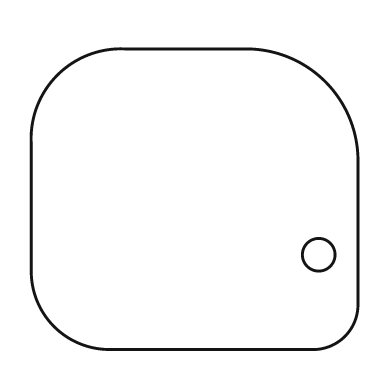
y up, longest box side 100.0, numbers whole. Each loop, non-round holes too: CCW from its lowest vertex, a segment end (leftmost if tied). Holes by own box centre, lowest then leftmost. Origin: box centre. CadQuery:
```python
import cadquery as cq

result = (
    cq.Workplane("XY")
    .moveTo(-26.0, -46.0)
    .lineTo(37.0, -46.0)
    .threePointArc((46.0, -42.0), (50.0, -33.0))
    .lineTo(50.0, 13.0)
    .threePointArc((40.0, 36.0), (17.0, 46.0))
    .lineTo(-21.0, 46.0)
    .threePointArc((-42.0, 38.0), (-50.0, 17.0))
    .lineTo(-50.0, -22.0)
    .threePointArc((-43.0, -39.0), (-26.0, -46.0))
    .close()
    .moveTo(38.0, -17.0)
    .circle(5.0)
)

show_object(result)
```